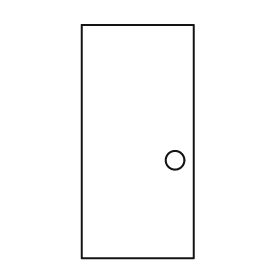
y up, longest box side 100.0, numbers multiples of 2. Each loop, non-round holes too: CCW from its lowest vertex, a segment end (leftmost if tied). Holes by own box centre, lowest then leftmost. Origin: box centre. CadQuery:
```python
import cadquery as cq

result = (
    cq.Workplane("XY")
    .moveTo(-24.0, -50.0)
    .lineTo(24.0, -50.0)
    .lineTo(24.0, 50.0)
    .lineTo(-24.0, 50.0)
    .close()
    .moveTo(16.0, -8.0)
    .circle(4.0)
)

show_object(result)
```